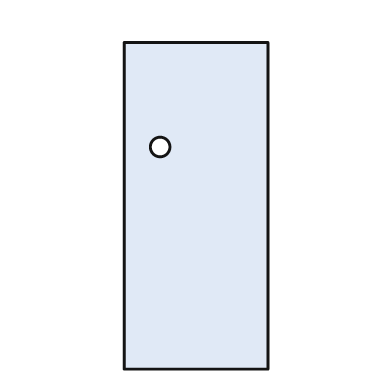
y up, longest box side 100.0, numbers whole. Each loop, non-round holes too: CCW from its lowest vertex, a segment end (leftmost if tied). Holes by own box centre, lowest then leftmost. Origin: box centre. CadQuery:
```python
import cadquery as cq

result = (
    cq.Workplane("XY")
    .moveTo(-22.0, -50.0)
    .lineTo(22.0, -50.0)
    .lineTo(22.0, 50.0)
    .lineTo(-22.0, 50.0)
    .close()
    .moveTo(-11.0, 18.0)
    .circle(3.0)
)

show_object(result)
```